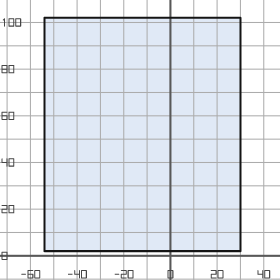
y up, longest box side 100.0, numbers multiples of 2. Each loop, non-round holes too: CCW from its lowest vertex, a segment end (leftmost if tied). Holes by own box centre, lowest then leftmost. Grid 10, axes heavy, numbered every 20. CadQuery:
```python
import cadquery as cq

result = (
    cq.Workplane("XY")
    .moveTo(-54.0, 2.0)
    .lineTo(30.0, 2.0)
    .lineTo(30.0, 102.0)
    .lineTo(-54.0, 102.0)
    .close()
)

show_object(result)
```